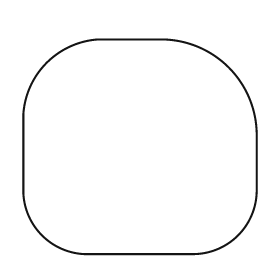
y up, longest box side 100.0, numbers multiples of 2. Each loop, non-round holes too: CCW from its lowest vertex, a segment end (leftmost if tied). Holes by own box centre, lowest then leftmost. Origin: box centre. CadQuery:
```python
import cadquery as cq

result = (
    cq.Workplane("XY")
    .moveTo(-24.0, -46.0)
    .lineTo(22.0, -46.0)
    .threePointArc((42.0, -38.0), (50.0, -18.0))
    .lineTo(50.0, 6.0)
    .threePointArc((38.0, 34.0), (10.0, 46.0))
    .lineTo(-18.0, 46.0)
    .threePointArc((-40.0, 36.0), (-50.0, 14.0))
    .lineTo(-50.0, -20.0)
    .threePointArc((-42.0, -38.0), (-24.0, -46.0))
    .close()
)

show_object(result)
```